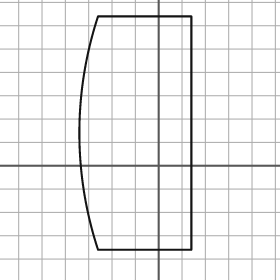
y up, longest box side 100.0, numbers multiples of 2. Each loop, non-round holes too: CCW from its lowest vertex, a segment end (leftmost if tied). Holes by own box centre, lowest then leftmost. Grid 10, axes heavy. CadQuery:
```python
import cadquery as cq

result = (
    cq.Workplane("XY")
    .moveTo(-26.0, -36.0)
    .lineTo(14.0, -36.0)
    .lineTo(14.0, 64.0)
    .lineTo(-26.0, 64.0)
    .threePointArc((-34.0, 14.0), (-26.0, -36.0))
    .close()
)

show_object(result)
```